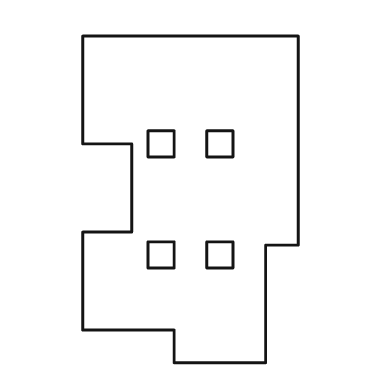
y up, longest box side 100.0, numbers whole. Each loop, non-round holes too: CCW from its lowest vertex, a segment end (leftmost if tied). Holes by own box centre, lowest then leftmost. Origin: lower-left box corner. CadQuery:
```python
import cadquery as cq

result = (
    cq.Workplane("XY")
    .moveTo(28.0, 0.0)
    .lineTo(56.0, 0.0)
    .lineTo(56.0, 36.0)
    .lineTo(66.0, 36.0)
    .lineTo(66.0, 100.0)
    .lineTo(0.0, 100.0)
    .lineTo(0.0, 67.0)
    .lineTo(15.0, 67.0)
    .lineTo(15.0, 40.0)
    .lineTo(0.0, 40.0)
    .lineTo(0.0, 10.0)
    .lineTo(28.0, 10.0)
    .close()
    .moveTo(20.0, 29.0)
    .lineTo(28.0, 29.0)
    .lineTo(28.0, 37.0)
    .lineTo(20.0, 37.0)
    .close()
    .moveTo(38.0, 29.0)
    .lineTo(46.0, 29.0)
    .lineTo(46.0, 37.0)
    .lineTo(38.0, 37.0)
    .close()
    .moveTo(20.0, 63.0)
    .lineTo(28.0, 63.0)
    .lineTo(28.0, 71.0)
    .lineTo(20.0, 71.0)
    .close()
    .moveTo(38.0, 63.0)
    .lineTo(46.0, 63.0)
    .lineTo(46.0, 71.0)
    .lineTo(38.0, 71.0)
    .close()
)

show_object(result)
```